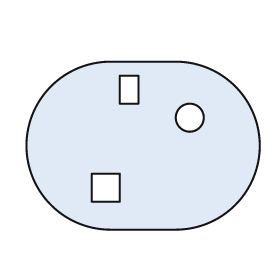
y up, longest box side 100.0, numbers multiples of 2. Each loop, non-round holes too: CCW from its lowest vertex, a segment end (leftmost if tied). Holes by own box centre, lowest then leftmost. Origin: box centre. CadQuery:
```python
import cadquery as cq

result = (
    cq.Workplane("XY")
    .moveTo(-14.0, -36.0)
    .lineTo(14.0, -36.0)
    .threePointArc((50.0, 0.0), (14.0, 36.0))
    .lineTo(-14.0, 36.0)
    .threePointArc((-50.0, 0.0), (-14.0, -36.0))
    .close()
    .moveTo(-22.0, -24.0)
    .lineTo(-10.0, -24.0)
    .lineTo(-10.0, -12.0)
    .lineTo(-22.0, -12.0)
    .close()
    .moveTo(20.0, 12.0)
    .circle(6.0)
    .moveTo(-10.0, 18.0)
    .lineTo(-2.0, 18.0)
    .lineTo(-2.0, 30.0)
    .lineTo(-10.0, 30.0)
    .close()
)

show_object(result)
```